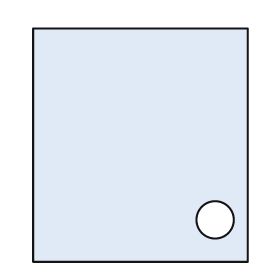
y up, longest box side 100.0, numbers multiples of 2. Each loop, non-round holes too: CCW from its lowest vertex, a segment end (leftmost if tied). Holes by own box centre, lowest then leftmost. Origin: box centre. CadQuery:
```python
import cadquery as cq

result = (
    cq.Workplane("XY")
    .moveTo(-46.0, -50.0)
    .lineTo(46.0, -50.0)
    .lineTo(46.0, 50.0)
    .lineTo(-46.0, 50.0)
    .close()
    .moveTo(32.0, -32.0)
    .circle(8.0)
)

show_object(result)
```